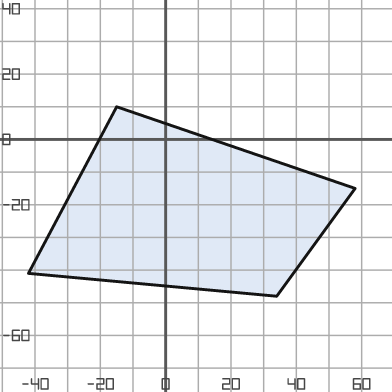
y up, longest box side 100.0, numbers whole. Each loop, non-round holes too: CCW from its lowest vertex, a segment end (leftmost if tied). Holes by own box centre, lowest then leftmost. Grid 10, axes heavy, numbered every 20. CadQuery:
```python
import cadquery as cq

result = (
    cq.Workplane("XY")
    .moveTo(34.0, -48.0)
    .lineTo(58.0, -15.0)
    .lineTo(-15.0, 10.0)
    .lineTo(-42.0, -41.0)
    .close()
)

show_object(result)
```